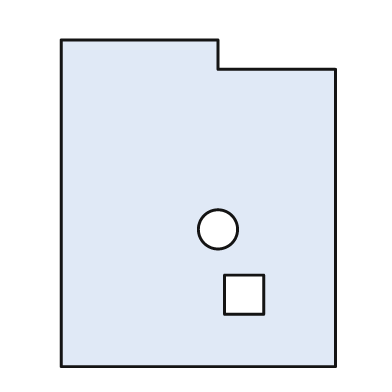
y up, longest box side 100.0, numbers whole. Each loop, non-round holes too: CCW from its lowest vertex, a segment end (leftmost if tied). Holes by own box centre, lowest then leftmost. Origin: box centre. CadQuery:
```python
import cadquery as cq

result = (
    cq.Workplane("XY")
    .moveTo(-42.0, -50.0)
    .lineTo(42.0, -50.0)
    .lineTo(42.0, 41.0)
    .lineTo(6.0, 41.0)
    .lineTo(6.0, 50.0)
    .lineTo(-42.0, 50.0)
    .close()
    .moveTo(8.0, -34.0)
    .lineTo(20.0, -34.0)
    .lineTo(20.0, -22.0)
    .lineTo(8.0, -22.0)
    .close()
    .moveTo(6.0, -8.0)
    .circle(6.0)
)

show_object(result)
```